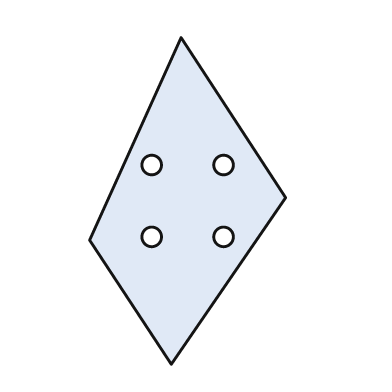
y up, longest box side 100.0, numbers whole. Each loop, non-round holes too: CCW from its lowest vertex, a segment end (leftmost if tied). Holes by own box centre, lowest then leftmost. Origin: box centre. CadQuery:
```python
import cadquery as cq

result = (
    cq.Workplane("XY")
    .moveTo(-5.0, -50.0)
    .lineTo(30.0, 1.0)
    .lineTo(-2.0, 50.0)
    .lineTo(-30.0, -12.0)
    .close()
    .moveTo(-11.0, -11.0)
    .circle(3.0)
    .moveTo(11.0, -11.0)
    .circle(3.0)
    .moveTo(-11.0, 11.0)
    .circle(3.0)
    .moveTo(11.0, 11.0)
    .circle(3.0)
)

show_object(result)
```